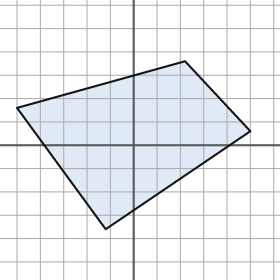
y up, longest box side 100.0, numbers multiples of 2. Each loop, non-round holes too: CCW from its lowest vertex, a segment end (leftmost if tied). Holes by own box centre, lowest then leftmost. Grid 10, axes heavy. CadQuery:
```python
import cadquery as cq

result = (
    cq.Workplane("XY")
    .moveTo(-12.0, -36.0)
    .lineTo(50.0, 6.0)
    .lineTo(22.0, 36.0)
    .lineTo(-50.0, 16.0)
    .close()
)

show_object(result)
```